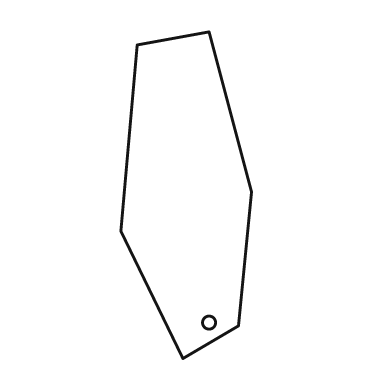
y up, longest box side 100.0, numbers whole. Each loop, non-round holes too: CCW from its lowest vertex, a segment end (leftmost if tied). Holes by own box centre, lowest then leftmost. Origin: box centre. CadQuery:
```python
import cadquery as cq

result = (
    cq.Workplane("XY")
    .moveTo(-1.0, -50.0)
    .lineTo(16.0, -40.0)
    .lineTo(20.0, 1.0)
    .lineTo(7.0, 50.0)
    .lineTo(-15.0, 46.0)
    .lineTo(-20.0, -11.0)
    .close()
    .moveTo(7.0, -39.0)
    .circle(2.0)
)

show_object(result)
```